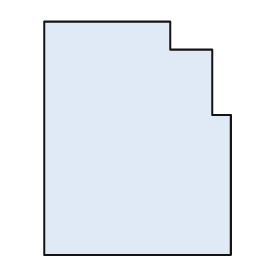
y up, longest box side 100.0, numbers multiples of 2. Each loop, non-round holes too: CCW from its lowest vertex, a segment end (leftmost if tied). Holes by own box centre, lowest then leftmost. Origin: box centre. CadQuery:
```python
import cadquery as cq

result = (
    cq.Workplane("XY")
    .moveTo(-40.0, -50.0)
    .lineTo(40.0, -50.0)
    .lineTo(40.0, 10.0)
    .lineTo(32.0, 10.0)
    .lineTo(32.0, 38.0)
    .lineTo(14.0, 38.0)
    .lineTo(14.0, 50.0)
    .lineTo(-40.0, 50.0)
    .close()
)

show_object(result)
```